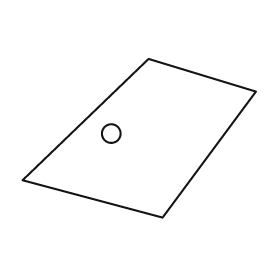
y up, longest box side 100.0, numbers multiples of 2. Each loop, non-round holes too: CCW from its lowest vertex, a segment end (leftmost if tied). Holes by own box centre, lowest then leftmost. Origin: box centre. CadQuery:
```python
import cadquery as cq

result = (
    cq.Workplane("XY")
    .moveTo(10.0, -34.0)
    .lineTo(50.0, 20.0)
    .lineTo(4.0, 34.0)
    .lineTo(-50.0, -18.0)
    .close()
    .moveTo(-12.0, 2.0)
    .circle(4.0)
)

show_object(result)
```